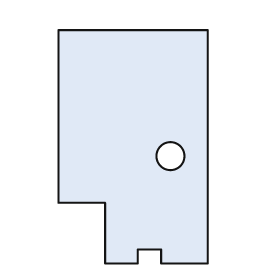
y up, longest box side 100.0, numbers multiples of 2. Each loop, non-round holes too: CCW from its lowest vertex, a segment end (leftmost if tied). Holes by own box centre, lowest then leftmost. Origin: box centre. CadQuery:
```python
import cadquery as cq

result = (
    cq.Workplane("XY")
    .moveTo(-12.0, -50.0)
    .lineTo(2.0, -50.0)
    .lineTo(2.0, -44.0)
    .lineTo(12.0, -44.0)
    .lineTo(12.0, -50.0)
    .lineTo(32.0, -50.0)
    .lineTo(32.0, 50.0)
    .lineTo(-32.0, 50.0)
    .lineTo(-32.0, -24.0)
    .lineTo(-12.0, -24.0)
    .close()
    .moveTo(16.0, -4.0)
    .circle(6.0)
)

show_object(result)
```